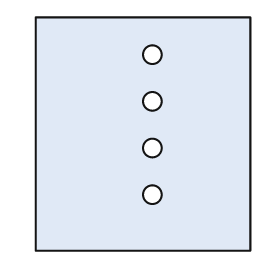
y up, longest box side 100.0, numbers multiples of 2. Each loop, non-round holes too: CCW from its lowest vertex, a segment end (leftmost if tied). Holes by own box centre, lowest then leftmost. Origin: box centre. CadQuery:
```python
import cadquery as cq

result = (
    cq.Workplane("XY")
    .moveTo(-46.0, -50.0)
    .lineTo(46.0, -50.0)
    .lineTo(46.0, 50.0)
    .lineTo(-46.0, 50.0)
    .close()
    .moveTo(4.0, -26.0)
    .circle(4.0)
    .moveTo(4.0, -6.0)
    .circle(4.0)
    .moveTo(4.0, 14.0)
    .circle(4.0)
    .moveTo(4.0, 34.0)
    .circle(4.0)
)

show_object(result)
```